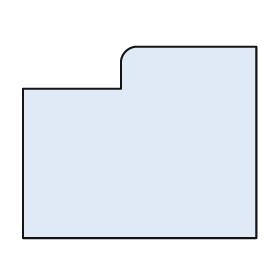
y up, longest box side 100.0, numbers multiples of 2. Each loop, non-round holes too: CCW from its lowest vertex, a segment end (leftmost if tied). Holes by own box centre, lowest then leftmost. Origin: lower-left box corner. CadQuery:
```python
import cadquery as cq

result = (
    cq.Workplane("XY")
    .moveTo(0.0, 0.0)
    .lineTo(100.0, 0.0)
    .lineTo(100.0, 82.0)
    .lineTo(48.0, 82.0)
    .threePointArc((44.0, 80.0), (42.0, 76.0))
    .lineTo(42.0, 64.0)
    .lineTo(0.0, 64.0)
    .close()
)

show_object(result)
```